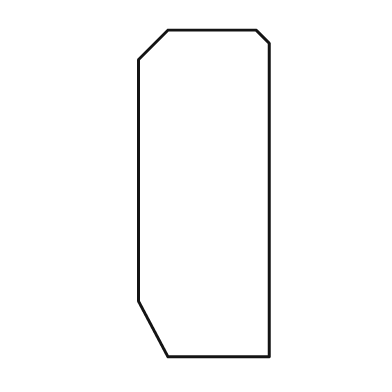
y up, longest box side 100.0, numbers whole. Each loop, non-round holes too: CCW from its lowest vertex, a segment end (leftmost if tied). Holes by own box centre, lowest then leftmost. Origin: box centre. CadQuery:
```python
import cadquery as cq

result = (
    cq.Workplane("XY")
    .moveTo(-11.0, -50.0)
    .lineTo(20.0, -50.0)
    .lineTo(20.0, 46.0)
    .lineTo(16.0, 50.0)
    .lineTo(-11.0, 50.0)
    .lineTo(-20.0, 41.0)
    .lineTo(-20.0, -33.0)
    .close()
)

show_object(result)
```